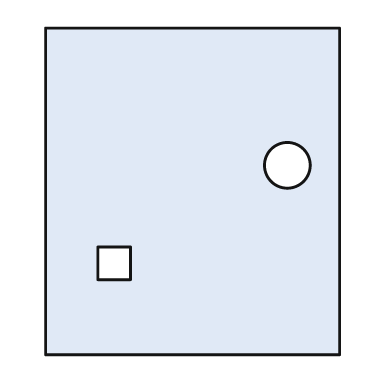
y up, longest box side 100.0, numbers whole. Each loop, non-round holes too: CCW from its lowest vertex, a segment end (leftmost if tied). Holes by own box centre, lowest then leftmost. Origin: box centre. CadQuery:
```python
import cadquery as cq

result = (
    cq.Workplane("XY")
    .moveTo(-45.0, -50.0)
    .lineTo(45.0, -50.0)
    .lineTo(45.0, 50.0)
    .lineTo(-45.0, 50.0)
    .close()
    .moveTo(-29.0, -27.0)
    .lineTo(-19.0, -27.0)
    .lineTo(-19.0, -17.0)
    .lineTo(-29.0, -17.0)
    .close()
    .moveTo(29.0, 8.0)
    .circle(7.0)
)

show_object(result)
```